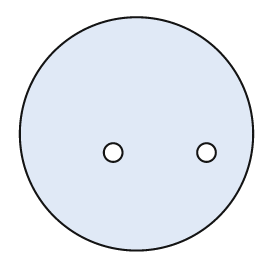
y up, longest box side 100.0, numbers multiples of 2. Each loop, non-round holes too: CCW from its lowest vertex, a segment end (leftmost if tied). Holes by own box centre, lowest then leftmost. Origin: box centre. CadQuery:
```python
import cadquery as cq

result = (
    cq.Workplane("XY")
    .moveTo(0.0, 0.0)
    .circle(50.0)
    .moveTo(-10.0, -8.0)
    .circle(4.0)
    .moveTo(30.0, -8.0)
    .circle(4.0)
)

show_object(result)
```